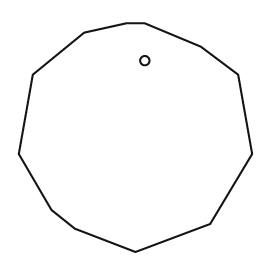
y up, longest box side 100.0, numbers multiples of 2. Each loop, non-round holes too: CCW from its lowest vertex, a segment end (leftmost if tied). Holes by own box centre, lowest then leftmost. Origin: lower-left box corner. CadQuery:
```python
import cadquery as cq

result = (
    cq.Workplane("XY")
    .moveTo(50.0, 0.0)
    .lineTo(82.0, 12.0)
    .lineTo(100.0, 42.0)
    .lineTo(94.0, 76.0)
    .lineTo(78.0, 88.0)
    .lineTo(54.0, 98.0)
    .lineTo(46.0, 98.0)
    .lineTo(28.0, 94.0)
    .lineTo(6.0, 76.0)
    .lineTo(0.0, 42.0)
    .lineTo(14.0, 18.0)
    .lineTo(24.0, 10.0)
    .close()
    .moveTo(54.0, 82.0)
    .circle(2.0)
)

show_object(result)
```